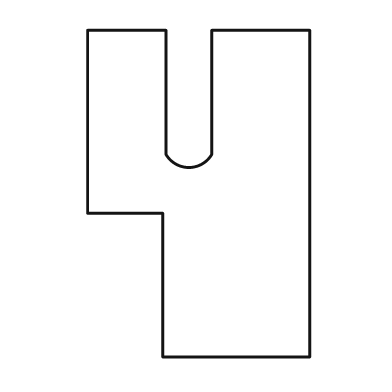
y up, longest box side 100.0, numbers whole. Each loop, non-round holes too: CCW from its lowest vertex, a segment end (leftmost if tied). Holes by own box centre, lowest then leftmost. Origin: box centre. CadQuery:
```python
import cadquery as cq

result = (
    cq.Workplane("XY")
    .moveTo(-11.0, -50.0)
    .lineTo(34.0, -50.0)
    .lineTo(34.0, 50.0)
    .lineTo(4.0, 50.0)
    .lineTo(4.0, 12.0)
    .threePointArc((-3.0, 8.0), (-10.0, 12.0))
    .lineTo(-10.0, 50.0)
    .lineTo(-34.0, 50.0)
    .lineTo(-34.0, -6.0)
    .lineTo(-11.0, -6.0)
    .close()
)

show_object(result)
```